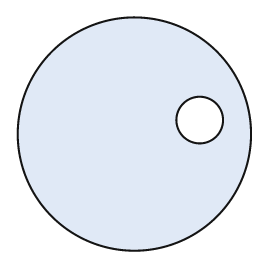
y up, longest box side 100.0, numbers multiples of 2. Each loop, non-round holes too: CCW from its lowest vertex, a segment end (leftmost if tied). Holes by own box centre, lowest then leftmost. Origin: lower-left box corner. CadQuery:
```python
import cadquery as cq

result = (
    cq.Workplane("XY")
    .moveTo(50.0, 50.0)
    .circle(50.0)
    .moveTo(78.0, 56.0)
    .circle(10.0)
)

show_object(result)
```